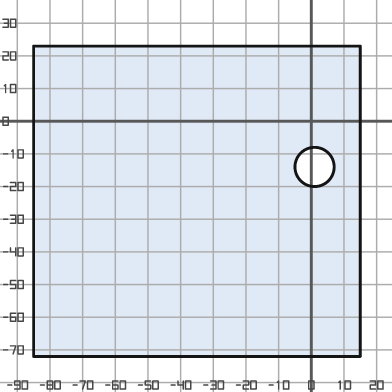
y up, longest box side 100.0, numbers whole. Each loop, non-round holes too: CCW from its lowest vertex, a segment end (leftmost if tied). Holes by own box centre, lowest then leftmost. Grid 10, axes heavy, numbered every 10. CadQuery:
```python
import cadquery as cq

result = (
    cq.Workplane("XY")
    .moveTo(-85.0, -72.0)
    .lineTo(15.0, -72.0)
    .lineTo(15.0, 23.0)
    .lineTo(-85.0, 23.0)
    .close()
    .moveTo(1.0, -14.0)
    .circle(6.0)
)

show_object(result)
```